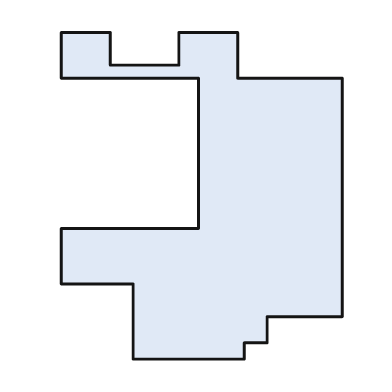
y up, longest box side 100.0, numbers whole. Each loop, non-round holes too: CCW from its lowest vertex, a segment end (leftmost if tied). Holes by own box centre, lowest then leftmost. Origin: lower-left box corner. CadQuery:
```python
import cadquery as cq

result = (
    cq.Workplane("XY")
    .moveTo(22.0, 0.0)
    .lineTo(56.0, 0.0)
    .lineTo(56.0, 5.0)
    .lineTo(63.0, 5.0)
    .lineTo(63.0, 13.0)
    .lineTo(86.0, 13.0)
    .lineTo(86.0, 86.0)
    .lineTo(54.0, 86.0)
    .lineTo(54.0, 100.0)
    .lineTo(36.0, 100.0)
    .lineTo(36.0, 90.0)
    .lineTo(15.0, 90.0)
    .lineTo(15.0, 100.0)
    .lineTo(0.0, 100.0)
    .lineTo(0.0, 86.0)
    .lineTo(42.0, 86.0)
    .lineTo(42.0, 40.0)
    .lineTo(0.0, 40.0)
    .lineTo(0.0, 23.0)
    .lineTo(22.0, 23.0)
    .close()
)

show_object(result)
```